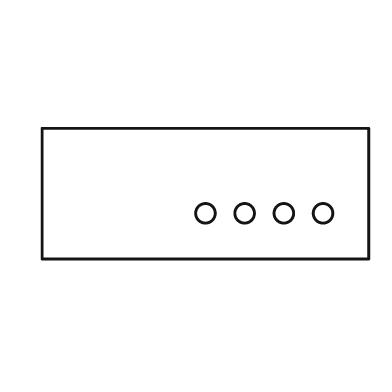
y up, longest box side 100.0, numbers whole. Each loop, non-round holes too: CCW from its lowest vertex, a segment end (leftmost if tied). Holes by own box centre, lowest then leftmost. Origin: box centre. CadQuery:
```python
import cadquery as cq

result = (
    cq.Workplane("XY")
    .moveTo(-50.0, -20.0)
    .lineTo(50.0, -20.0)
    .lineTo(50.0, 20.0)
    .lineTo(-50.0, 20.0)
    .close()
    .moveTo(0.0, -6.0)
    .circle(3.0)
    .moveTo(12.0, -6.0)
    .circle(3.0)
    .moveTo(24.0, -6.0)
    .circle(3.0)
    .moveTo(36.0, -6.0)
    .circle(3.0)
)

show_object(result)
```